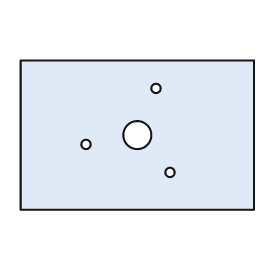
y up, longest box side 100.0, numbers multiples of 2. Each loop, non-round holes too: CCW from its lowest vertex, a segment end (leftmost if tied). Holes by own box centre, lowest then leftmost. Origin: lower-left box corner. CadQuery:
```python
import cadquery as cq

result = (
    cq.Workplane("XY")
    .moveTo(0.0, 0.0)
    .lineTo(100.0, 0.0)
    .lineTo(100.0, 64.0)
    .lineTo(0.0, 64.0)
    .close()
    .moveTo(64.0, 16.0)
    .circle(2.0)
    .moveTo(28.0, 28.0)
    .circle(2.0)
    .moveTo(50.0, 32.0)
    .circle(6.0)
    .moveTo(58.0, 52.0)
    .circle(2.0)
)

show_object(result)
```